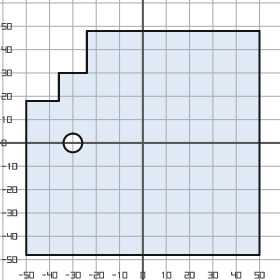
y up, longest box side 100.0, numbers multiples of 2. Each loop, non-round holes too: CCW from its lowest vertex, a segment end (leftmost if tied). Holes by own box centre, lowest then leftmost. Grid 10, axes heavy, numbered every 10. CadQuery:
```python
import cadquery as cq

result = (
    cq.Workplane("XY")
    .moveTo(-50.0, -48.0)
    .lineTo(50.0, -48.0)
    .lineTo(50.0, 48.0)
    .lineTo(-24.0, 48.0)
    .lineTo(-24.0, 30.0)
    .lineTo(-36.0, 30.0)
    .lineTo(-36.0, 18.0)
    .lineTo(-50.0, 18.0)
    .close()
    .moveTo(-30.0, 0.0)
    .circle(4.0)
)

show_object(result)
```